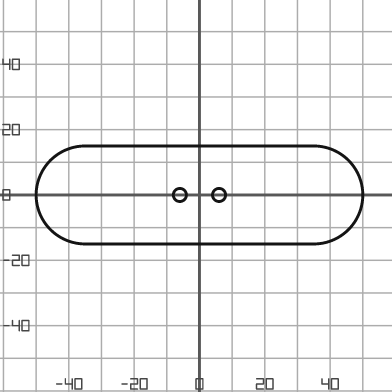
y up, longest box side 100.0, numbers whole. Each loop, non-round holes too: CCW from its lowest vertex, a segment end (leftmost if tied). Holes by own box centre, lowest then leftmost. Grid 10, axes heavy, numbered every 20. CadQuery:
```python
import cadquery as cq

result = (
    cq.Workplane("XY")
    .moveTo(-35.0, -15.0)
    .lineTo(35.0, -15.0)
    .threePointArc((50.0, 0.0), (35.0, 15.0))
    .lineTo(-35.0, 15.0)
    .threePointArc((-50.0, 0.0), (-35.0, -15.0))
    .close()
    .moveTo(-6.0, 0.0)
    .circle(2.0)
    .moveTo(6.0, 0.0)
    .circle(2.0)
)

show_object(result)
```